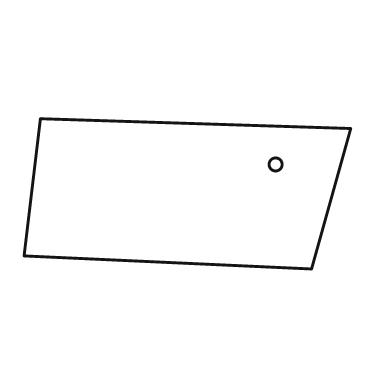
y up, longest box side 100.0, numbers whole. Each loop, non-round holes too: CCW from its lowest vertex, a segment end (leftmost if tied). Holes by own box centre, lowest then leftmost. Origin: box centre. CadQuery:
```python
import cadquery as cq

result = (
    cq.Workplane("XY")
    .moveTo(38.0, -23.0)
    .lineTo(50.0, 20.0)
    .lineTo(-45.0, 23.0)
    .lineTo(-50.0, -19.0)
    .close()
    .moveTo(27.0, 9.0)
    .circle(2.0)
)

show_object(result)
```